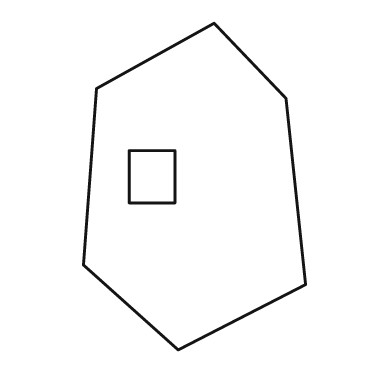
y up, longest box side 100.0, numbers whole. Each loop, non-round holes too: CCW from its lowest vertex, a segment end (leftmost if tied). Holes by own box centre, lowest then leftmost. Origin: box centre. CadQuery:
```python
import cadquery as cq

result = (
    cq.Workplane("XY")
    .moveTo(-5.0, -50.0)
    .lineTo(34.0, -30.0)
    .lineTo(28.0, 27.0)
    .lineTo(6.0, 50.0)
    .lineTo(-30.0, 30.0)
    .lineTo(-34.0, -24.0)
    .close()
    .moveTo(-20.0, -5.0)
    .lineTo(-6.0, -5.0)
    .lineTo(-6.0, 11.0)
    .lineTo(-20.0, 11.0)
    .close()
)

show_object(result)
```